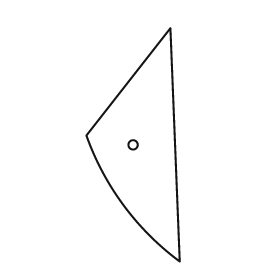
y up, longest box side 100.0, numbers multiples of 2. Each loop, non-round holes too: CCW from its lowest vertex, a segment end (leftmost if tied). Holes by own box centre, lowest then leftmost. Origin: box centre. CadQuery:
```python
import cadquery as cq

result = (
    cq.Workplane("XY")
    .moveTo(20.0, -50.0)
    .lineTo(16.0, 50.0)
    .lineTo(-20.0, 4.0)
    .threePointArc((-4.0, -26.0), (20.0, -50.0))
    .close()
    .moveTo(0.0, 0.0)
    .circle(2.0)
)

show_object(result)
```